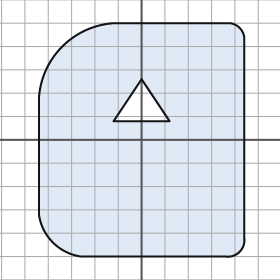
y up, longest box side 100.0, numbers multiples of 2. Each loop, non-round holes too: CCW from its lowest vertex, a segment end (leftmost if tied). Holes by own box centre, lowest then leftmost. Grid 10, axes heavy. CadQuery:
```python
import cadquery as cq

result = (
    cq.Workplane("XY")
    .moveTo(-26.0, -50.0)
    .lineTo(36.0, -50.0)
    .threePointArc((42.0, -48.0), (44.0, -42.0))
    .lineTo(44.0, 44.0)
    .threePointArc((42.0, 48.0), (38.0, 50.0))
    .lineTo(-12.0, 50.0)
    .threePointArc((-34.0, 40.0), (-44.0, 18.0))
    .lineTo(-44.0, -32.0)
    .threePointArc((-38.0, -44.0), (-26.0, -50.0))
    .close()
    .moveTo(-12.0, 8.0)
    .lineTo(12.0, 8.0)
    .lineTo(0.0, 26.0)
    .close()
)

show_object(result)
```